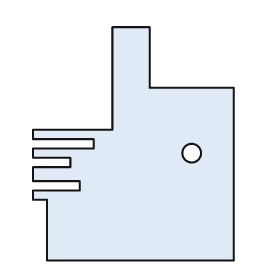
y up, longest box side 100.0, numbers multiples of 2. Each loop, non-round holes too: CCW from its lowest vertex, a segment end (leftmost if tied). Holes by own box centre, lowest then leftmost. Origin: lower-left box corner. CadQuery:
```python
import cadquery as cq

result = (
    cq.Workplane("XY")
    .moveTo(6.0, 0.0)
    .lineTo(86.0, 0.0)
    .lineTo(86.0, 74.0)
    .lineTo(50.0, 74.0)
    .lineTo(50.0, 100.0)
    .lineTo(34.0, 100.0)
    .lineTo(34.0, 56.0)
    .lineTo(0.0, 56.0)
    .lineTo(0.0, 52.0)
    .lineTo(26.0, 52.0)
    .lineTo(26.0, 48.0)
    .lineTo(0.0, 48.0)
    .lineTo(0.0, 44.0)
    .lineTo(16.0, 44.0)
    .lineTo(16.0, 40.0)
    .lineTo(0.0, 40.0)
    .lineTo(0.0, 34.0)
    .lineTo(20.0, 34.0)
    .lineTo(20.0, 30.0)
    .lineTo(0.0, 30.0)
    .lineTo(0.0, 26.0)
    .lineTo(6.0, 26.0)
    .close()
    .moveTo(68.0, 46.0)
    .circle(4.0)
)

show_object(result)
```